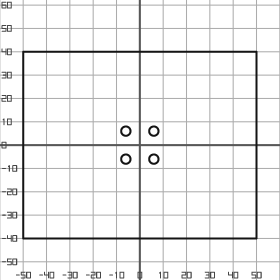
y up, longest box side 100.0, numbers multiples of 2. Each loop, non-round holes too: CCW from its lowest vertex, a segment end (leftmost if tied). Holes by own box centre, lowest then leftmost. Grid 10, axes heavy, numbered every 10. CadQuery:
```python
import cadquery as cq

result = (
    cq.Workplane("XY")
    .moveTo(-50.0, -40.0)
    .lineTo(50.0, -40.0)
    .lineTo(50.0, 40.0)
    .lineTo(-50.0, 40.0)
    .close()
    .moveTo(-6.0, -6.0)
    .circle(2.0)
    .moveTo(6.0, -6.0)
    .circle(2.0)
    .moveTo(-6.0, 6.0)
    .circle(2.0)
    .moveTo(6.0, 6.0)
    .circle(2.0)
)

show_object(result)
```